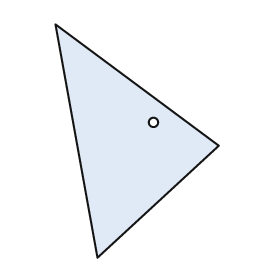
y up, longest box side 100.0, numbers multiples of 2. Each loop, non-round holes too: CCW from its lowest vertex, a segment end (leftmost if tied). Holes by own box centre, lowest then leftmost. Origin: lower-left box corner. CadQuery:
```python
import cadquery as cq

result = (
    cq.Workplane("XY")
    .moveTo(18.0, 0.0)
    .lineTo(70.0, 48.0)
    .lineTo(0.0, 100.0)
    .close()
    .moveTo(42.0, 58.0)
    .circle(2.0)
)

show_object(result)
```